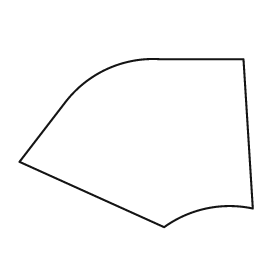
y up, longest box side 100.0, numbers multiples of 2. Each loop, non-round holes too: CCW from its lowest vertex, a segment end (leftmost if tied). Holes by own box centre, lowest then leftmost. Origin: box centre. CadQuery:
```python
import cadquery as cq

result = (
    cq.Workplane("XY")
    .moveTo(12.0, -36.0)
    .threePointArc((30.0, -28.0), (50.0, -28.0))
    .lineTo(46.0, 36.0)
    .lineTo(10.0, 36.0)
    .threePointArc((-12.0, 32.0), (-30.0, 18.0))
    .lineTo(-50.0, -8.0)
    .close()
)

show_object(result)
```